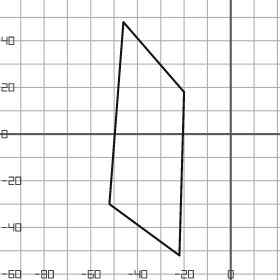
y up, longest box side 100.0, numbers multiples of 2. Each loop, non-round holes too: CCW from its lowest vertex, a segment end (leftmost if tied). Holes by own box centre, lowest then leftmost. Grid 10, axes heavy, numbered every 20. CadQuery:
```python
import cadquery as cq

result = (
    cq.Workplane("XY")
    .moveTo(-22.0, -52.0)
    .lineTo(-20.0, 18.0)
    .lineTo(-46.0, 48.0)
    .lineTo(-52.0, -30.0)
    .close()
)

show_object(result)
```